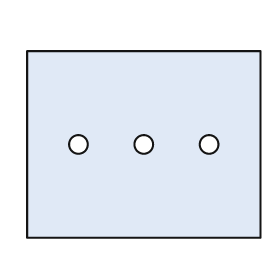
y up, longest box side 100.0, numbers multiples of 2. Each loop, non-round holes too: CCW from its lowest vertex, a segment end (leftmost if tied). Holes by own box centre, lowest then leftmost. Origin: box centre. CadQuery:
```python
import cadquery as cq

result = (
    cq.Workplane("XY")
    .moveTo(-50.0, -40.0)
    .lineTo(50.0, -40.0)
    .lineTo(50.0, 40.0)
    .lineTo(-50.0, 40.0)
    .close()
    .moveTo(-28.0, 0.0)
    .circle(4.0)
    .moveTo(0.0, 0.0)
    .circle(4.0)
    .moveTo(28.0, 0.0)
    .circle(4.0)
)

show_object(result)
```